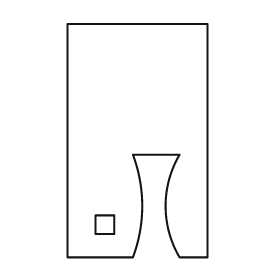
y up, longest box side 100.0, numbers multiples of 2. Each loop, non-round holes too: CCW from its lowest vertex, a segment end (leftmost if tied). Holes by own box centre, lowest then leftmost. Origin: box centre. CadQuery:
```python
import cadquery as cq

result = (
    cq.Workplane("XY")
    .moveTo(-30.0, -50.0)
    .lineTo(-2.0, -50.0)
    .threePointArc((2.0, -28.0), (-2.0, -6.0))
    .lineTo(18.0, -6.0)
    .threePointArc((12.0, -28.0), (18.0, -50.0))
    .lineTo(30.0, -50.0)
    .lineTo(30.0, 50.0)
    .lineTo(-30.0, 50.0)
    .close()
    .moveTo(-18.0, -40.0)
    .lineTo(-10.0, -40.0)
    .lineTo(-10.0, -32.0)
    .lineTo(-18.0, -32.0)
    .close()
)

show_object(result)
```